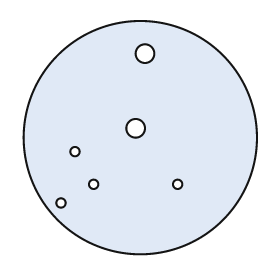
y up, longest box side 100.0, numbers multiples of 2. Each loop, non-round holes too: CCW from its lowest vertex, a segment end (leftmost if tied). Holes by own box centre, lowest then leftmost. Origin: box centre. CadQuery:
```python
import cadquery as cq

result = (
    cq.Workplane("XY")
    .moveTo(0.0, 0.0)
    .circle(50.0)
    .moveTo(-34.0, -28.0)
    .circle(2.0)
    .moveTo(-20.0, -20.0)
    .circle(2.0)
    .moveTo(16.0, -20.0)
    .circle(2.0)
    .moveTo(-28.0, -6.0)
    .circle(2.0)
    .moveTo(-2.0, 4.0)
    .circle(4.0)
    .moveTo(2.0, 36.0)
    .circle(4.0)
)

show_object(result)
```